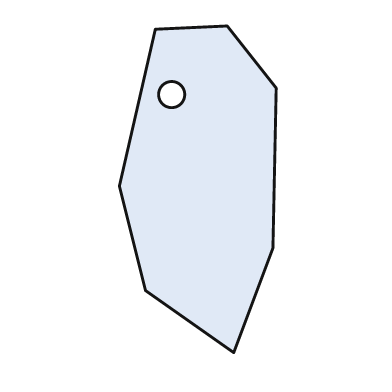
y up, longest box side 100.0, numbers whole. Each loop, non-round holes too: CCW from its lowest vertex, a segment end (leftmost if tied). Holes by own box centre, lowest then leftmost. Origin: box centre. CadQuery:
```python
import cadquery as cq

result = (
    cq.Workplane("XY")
    .moveTo(11.0, -50.0)
    .lineTo(23.0, -18.0)
    .lineTo(24.0, 31.0)
    .lineTo(9.0, 50.0)
    .lineTo(-13.0, 49.0)
    .lineTo(-24.0, 1.0)
    .lineTo(-16.0, -31.0)
    .close()
    .moveTo(-8.0, 29.0)
    .circle(4.0)
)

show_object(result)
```